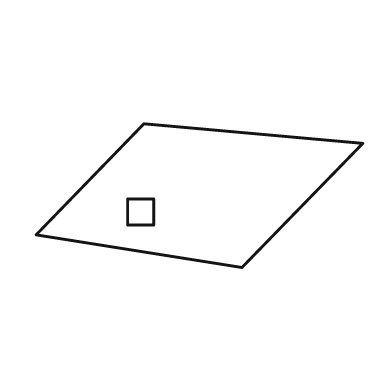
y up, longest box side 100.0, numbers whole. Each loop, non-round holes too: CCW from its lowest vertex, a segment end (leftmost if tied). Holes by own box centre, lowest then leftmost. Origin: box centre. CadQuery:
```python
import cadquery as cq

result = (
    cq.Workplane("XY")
    .moveTo(13.0, -22.0)
    .lineTo(50.0, 16.0)
    .lineTo(-17.0, 22.0)
    .lineTo(-50.0, -12.0)
    .close()
    .moveTo(-22.0, -9.0)
    .lineTo(-14.0, -9.0)
    .lineTo(-14.0, -1.0)
    .lineTo(-22.0, -1.0)
    .close()
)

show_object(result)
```